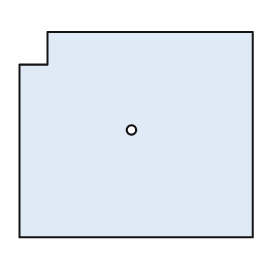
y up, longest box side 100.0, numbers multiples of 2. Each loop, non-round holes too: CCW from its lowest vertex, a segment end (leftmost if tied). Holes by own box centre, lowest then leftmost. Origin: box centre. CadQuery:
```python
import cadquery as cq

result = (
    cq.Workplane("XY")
    .moveTo(-50.0, -44.0)
    .lineTo(50.0, -44.0)
    .lineTo(50.0, 44.0)
    .lineTo(-38.0, 44.0)
    .lineTo(-38.0, 30.0)
    .lineTo(-50.0, 30.0)
    .close()
    .moveTo(-2.0, 2.0)
    .circle(2.0)
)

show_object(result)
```